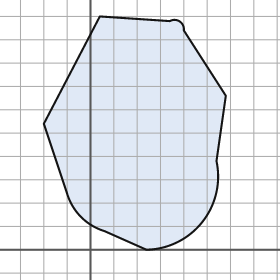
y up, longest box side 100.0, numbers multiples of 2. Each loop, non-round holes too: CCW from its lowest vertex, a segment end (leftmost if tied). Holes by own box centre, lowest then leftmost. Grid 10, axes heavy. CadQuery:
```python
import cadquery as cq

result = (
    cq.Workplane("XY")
    .moveTo(24.0, 0.0)
    .threePointArc((48.0, 12.0), (54.0, 38.0))
    .lineTo(58.0, 66.0)
    .lineTo(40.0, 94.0)
    .threePointArc((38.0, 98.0), (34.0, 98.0))
    .lineTo(4.0, 100.0)
    .lineTo(-20.0, 54.0)
    .lineTo(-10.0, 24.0)
    .threePointArc((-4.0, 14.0), (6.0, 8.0))
    .close()
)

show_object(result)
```